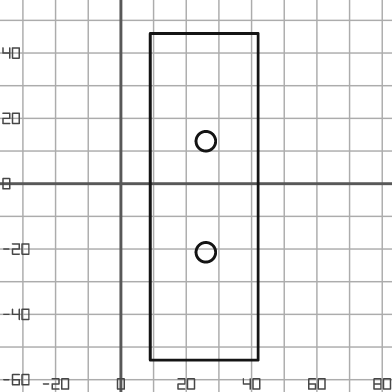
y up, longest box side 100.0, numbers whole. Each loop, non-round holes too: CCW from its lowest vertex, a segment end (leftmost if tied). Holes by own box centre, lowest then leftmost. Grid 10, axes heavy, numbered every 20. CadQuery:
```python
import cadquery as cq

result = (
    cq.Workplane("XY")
    .moveTo(9.0, -54.0)
    .lineTo(42.0, -54.0)
    .lineTo(42.0, 46.0)
    .lineTo(9.0, 46.0)
    .close()
    .moveTo(26.0, -21.0)
    .circle(3.0)
    .moveTo(26.0, 13.0)
    .circle(3.0)
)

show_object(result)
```